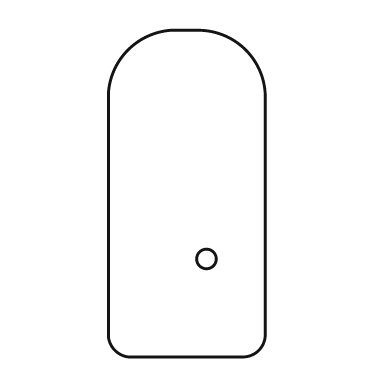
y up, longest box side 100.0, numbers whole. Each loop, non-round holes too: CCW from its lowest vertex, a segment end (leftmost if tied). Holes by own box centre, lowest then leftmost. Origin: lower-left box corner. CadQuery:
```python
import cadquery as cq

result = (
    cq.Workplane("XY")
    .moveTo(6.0, 0.0)
    .lineTo(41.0, 0.0)
    .threePointArc((46.0, 2.0), (48.0, 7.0))
    .lineTo(48.0, 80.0)
    .threePointArc((42.0, 94.0), (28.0, 100.0))
    .lineTo(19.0, 100.0)
    .threePointArc((6.0, 94.0), (0.0, 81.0))
    .lineTo(0.0, 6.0)
    .threePointArc((2.0, 2.0), (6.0, 0.0))
    .close()
    .moveTo(30.0, 30.0)
    .circle(3.0)
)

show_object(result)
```